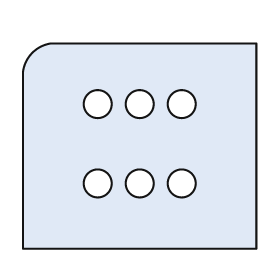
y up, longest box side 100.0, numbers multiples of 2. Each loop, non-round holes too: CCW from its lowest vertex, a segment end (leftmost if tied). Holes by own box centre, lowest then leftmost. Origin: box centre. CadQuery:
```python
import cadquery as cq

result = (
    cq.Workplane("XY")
    .moveTo(-50.0, -44.0)
    .lineTo(50.0, -44.0)
    .lineTo(50.0, 44.0)
    .lineTo(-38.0, 44.0)
    .threePointArc((-46.0, 40.0), (-50.0, 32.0))
    .close()
    .moveTo(-18.0, -16.0)
    .circle(6.0)
    .moveTo(0.0, -16.0)
    .circle(6.0)
    .moveTo(18.0, -16.0)
    .circle(6.0)
    .moveTo(-18.0, 18.0)
    .circle(6.0)
    .moveTo(0.0, 18.0)
    .circle(6.0)
    .moveTo(18.0, 18.0)
    .circle(6.0)
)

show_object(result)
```